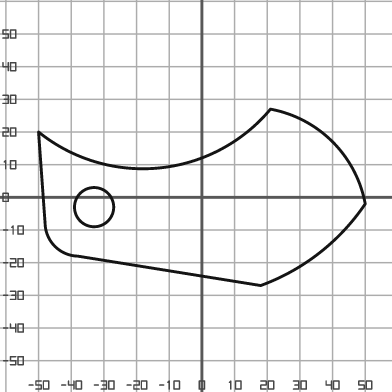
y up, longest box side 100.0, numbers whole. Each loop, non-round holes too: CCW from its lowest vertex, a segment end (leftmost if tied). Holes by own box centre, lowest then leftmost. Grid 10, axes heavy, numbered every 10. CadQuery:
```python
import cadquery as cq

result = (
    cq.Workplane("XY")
    .moveTo(18.0, -27.0)
    .threePointArc((36.0, -17.0), (50.0, -2.0))
    .threePointArc((40.0, 17.0), (21.0, 27.0))
    .threePointArc((-13.0, 9.0), (-50.0, 20.0))
    .lineTo(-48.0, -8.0)
    .threePointArc((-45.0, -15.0), (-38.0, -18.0))
    .close()
    .moveTo(-33.0, -3.0)
    .circle(6.0)
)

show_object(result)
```